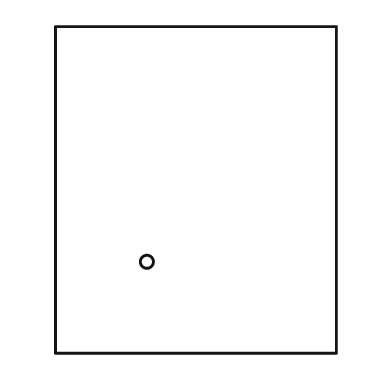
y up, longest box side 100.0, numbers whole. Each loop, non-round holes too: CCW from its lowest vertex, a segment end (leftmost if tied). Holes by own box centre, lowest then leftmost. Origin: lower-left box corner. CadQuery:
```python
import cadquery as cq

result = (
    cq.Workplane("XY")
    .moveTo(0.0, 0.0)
    .lineTo(86.0, 0.0)
    .lineTo(86.0, 100.0)
    .lineTo(0.0, 100.0)
    .close()
    .moveTo(28.0, 28.0)
    .circle(2.0)
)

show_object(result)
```